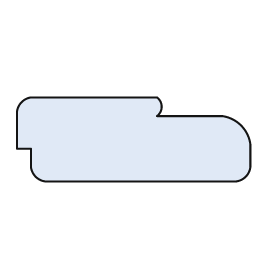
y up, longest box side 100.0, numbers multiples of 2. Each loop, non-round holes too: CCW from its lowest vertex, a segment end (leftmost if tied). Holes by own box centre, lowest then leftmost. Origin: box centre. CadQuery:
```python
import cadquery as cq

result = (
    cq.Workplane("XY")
    .moveTo(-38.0, -18.0)
    .lineTo(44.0, -18.0)
    .threePointArc((48.0, -16.0), (50.0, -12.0))
    .lineTo(50.0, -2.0)
    .threePointArc((46.0, 6.0), (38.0, 10.0))
    .lineTo(10.0, 10.0)
    .threePointArc((12.0, 14.0), (10.0, 18.0))
    .lineTo(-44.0, 18.0)
    .threePointArc((-48.0, 16.0), (-50.0, 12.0))
    .lineTo(-50.0, -4.0)
    .lineTo(-44.0, -4.0)
    .lineTo(-44.0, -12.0)
    .threePointArc((-42.0, -16.0), (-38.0, -18.0))
    .close()
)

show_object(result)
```